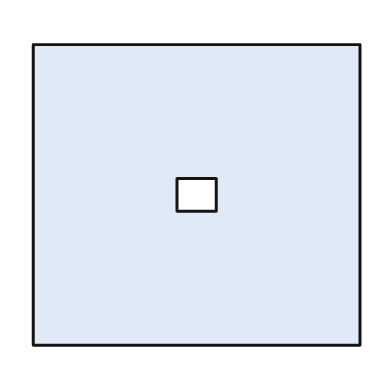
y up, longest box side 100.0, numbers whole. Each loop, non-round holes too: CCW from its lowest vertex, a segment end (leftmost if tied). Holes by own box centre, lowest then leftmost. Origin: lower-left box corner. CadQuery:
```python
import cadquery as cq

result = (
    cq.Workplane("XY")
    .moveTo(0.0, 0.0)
    .lineTo(100.0, 0.0)
    .lineTo(100.0, 92.0)
    .lineTo(0.0, 92.0)
    .close()
    .moveTo(44.0, 41.0)
    .lineTo(56.0, 41.0)
    .lineTo(56.0, 51.0)
    .lineTo(44.0, 51.0)
    .close()
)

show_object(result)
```